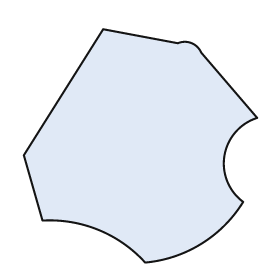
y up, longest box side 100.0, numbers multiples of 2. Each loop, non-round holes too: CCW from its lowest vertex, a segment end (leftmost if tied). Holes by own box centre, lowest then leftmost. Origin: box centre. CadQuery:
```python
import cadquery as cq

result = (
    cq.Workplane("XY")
    .moveTo(2.0, -50.0)
    .threePointArc((26.0, -42.0), (44.0, -24.0))
    .threePointArc((36.0, -4.0), (50.0, 12.0))
    .lineTo(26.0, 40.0)
    .threePointArc((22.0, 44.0), (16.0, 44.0))
    .lineTo(-16.0, 50.0)
    .lineTo(-50.0, -4.0)
    .lineTo(-42.0, -32.0)
    .threePointArc((-18.0, -36.0), (2.0, -50.0))
    .close()
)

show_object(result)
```